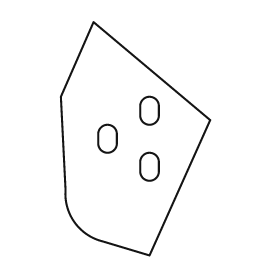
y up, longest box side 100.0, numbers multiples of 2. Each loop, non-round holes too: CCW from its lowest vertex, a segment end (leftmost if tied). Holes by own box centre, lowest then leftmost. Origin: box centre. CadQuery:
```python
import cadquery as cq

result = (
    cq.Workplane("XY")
    .moveTo(6.0, -50.0)
    .lineTo(32.0, 8.0)
    .lineTo(-18.0, 50.0)
    .lineTo(-32.0, 18.0)
    .lineTo(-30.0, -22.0)
    .threePointArc((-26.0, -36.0), (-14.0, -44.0))
    .close()
    .moveTo(2.0, -14.0)
    .threePointArc((6.0, -18.0), (10.0, -14.0))
    .lineTo(10.0, -10.0)
    .threePointArc((6.0, -6.0), (2.0, -10.0))
    .close()
    .moveTo(-16.0, -2.0)
    .threePointArc((-12.0, -6.0), (-8.0, -2.0))
    .lineTo(-8.0, 2.0)
    .threePointArc((-12.0, 6.0), (-16.0, 2.0))
    .close()
    .moveTo(2.0, 10.0)
    .threePointArc((6.0, 6.0), (10.0, 10.0))
    .lineTo(10.0, 14.0)
    .threePointArc((6.0, 18.0), (2.0, 14.0))
    .close()
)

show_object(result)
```